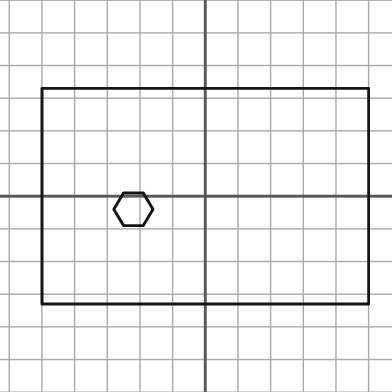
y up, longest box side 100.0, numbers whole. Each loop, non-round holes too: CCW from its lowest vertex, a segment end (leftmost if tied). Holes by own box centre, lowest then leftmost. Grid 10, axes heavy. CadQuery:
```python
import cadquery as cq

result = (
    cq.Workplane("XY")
    .moveTo(-50.0, -33.0)
    .lineTo(50.0, -33.0)
    .lineTo(50.0, 33.0)
    .lineTo(-50.0, 33.0)
    .close()
    .moveTo(-25.0, -9.0)
    .lineTo(-19.0, -9.0)
    .lineTo(-16.0, -4.0)
    .lineTo(-19.0, 1.0)
    .lineTo(-25.0, 1.0)
    .lineTo(-28.0, -4.0)
    .close()
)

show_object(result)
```